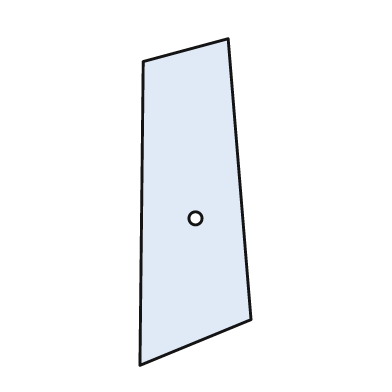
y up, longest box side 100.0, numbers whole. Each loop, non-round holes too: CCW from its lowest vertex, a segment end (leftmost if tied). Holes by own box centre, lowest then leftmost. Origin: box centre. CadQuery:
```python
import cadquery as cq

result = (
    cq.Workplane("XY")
    .moveTo(-17.0, -50.0)
    .lineTo(17.0, -36.0)
    .lineTo(10.0, 50.0)
    .lineTo(-16.0, 43.0)
    .close()
    .moveTo(0.0, -5.0)
    .circle(2.0)
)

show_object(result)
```